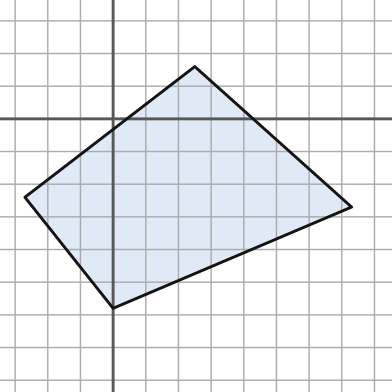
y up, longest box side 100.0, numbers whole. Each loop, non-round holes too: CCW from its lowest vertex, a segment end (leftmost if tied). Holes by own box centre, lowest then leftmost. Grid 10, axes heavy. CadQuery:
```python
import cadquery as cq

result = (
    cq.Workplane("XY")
    .moveTo(0.0, -58.0)
    .lineTo(73.0, -27.0)
    .lineTo(25.0, 16.0)
    .lineTo(-27.0, -24.0)
    .close()
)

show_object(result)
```